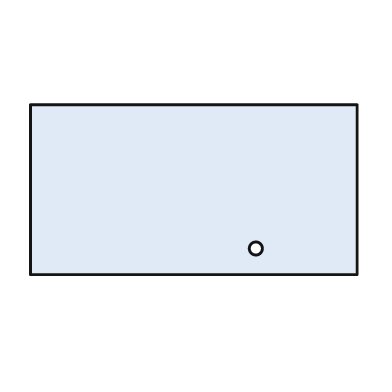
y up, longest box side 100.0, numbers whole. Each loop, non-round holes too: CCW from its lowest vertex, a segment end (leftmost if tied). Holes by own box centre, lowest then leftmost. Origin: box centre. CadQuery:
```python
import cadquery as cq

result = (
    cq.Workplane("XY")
    .moveTo(-50.0, -26.0)
    .lineTo(50.0, -26.0)
    .lineTo(50.0, 26.0)
    .lineTo(-50.0, 26.0)
    .close()
    .moveTo(19.0, -18.0)
    .circle(2.0)
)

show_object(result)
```